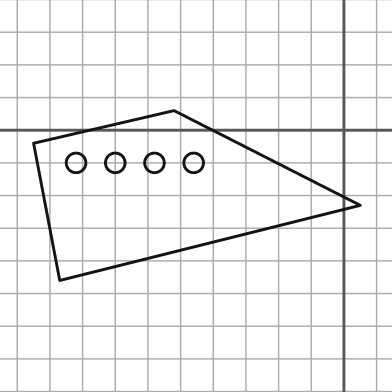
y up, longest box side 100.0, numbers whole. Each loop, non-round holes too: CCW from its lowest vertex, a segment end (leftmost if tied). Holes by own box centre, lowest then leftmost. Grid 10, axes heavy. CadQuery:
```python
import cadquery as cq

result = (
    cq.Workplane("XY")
    .moveTo(-87.0, -46.0)
    .lineTo(5.0, -23.0)
    .lineTo(-52.0, 6.0)
    .lineTo(-95.0, -4.0)
    .close()
    .moveTo(-82.0, -10.0)
    .circle(3.0)
    .moveTo(-70.0, -10.0)
    .circle(3.0)
    .moveTo(-58.0, -10.0)
    .circle(3.0)
    .moveTo(-46.0, -10.0)
    .circle(3.0)
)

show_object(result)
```